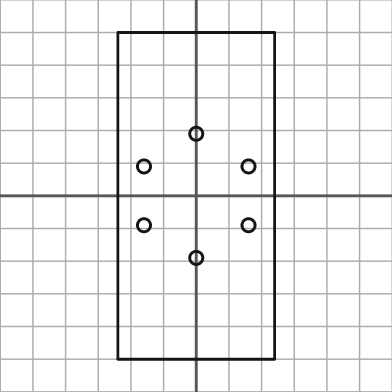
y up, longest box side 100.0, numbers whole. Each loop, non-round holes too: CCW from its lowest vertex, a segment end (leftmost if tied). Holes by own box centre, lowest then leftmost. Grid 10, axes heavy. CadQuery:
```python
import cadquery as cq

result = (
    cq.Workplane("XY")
    .moveTo(-24.0, -50.0)
    .lineTo(24.0, -50.0)
    .lineTo(24.0, 50.0)
    .lineTo(-24.0, 50.0)
    .close()
    .moveTo(0.0, -19.0)
    .circle(2.0)
    .moveTo(-16.0, -9.0)
    .circle(2.0)
    .moveTo(16.0, -9.0)
    .circle(2.0)
    .moveTo(-16.0, 9.0)
    .circle(2.0)
    .moveTo(16.0, 9.0)
    .circle(2.0)
    .moveTo(0.0, 19.0)
    .circle(2.0)
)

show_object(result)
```